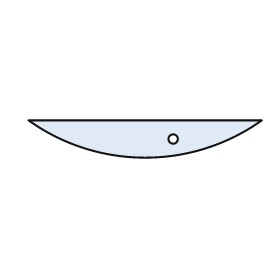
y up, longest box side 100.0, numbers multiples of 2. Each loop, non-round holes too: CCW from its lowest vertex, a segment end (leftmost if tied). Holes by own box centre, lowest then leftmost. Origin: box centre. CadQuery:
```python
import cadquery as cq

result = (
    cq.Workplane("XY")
    .moveTo(-50.0, 8.0)
    .threePointArc((0.0, -8.0), (50.0, 8.0))
    .close()
    .moveTo(12.0, 0.0)
    .circle(2.0)
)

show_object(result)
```